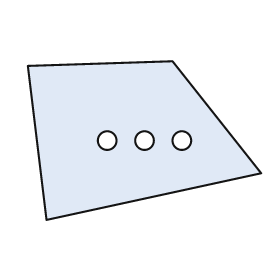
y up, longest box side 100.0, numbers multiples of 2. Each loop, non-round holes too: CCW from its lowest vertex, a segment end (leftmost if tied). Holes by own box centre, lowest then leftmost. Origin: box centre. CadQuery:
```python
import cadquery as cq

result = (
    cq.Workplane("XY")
    .moveTo(-42.0, -34.0)
    .lineTo(50.0, -14.0)
    .lineTo(12.0, 34.0)
    .lineTo(-50.0, 32.0)
    .close()
    .moveTo(-16.0, 0.0)
    .circle(4.0)
    .moveTo(0.0, 0.0)
    .circle(4.0)
    .moveTo(16.0, 0.0)
    .circle(4.0)
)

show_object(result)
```